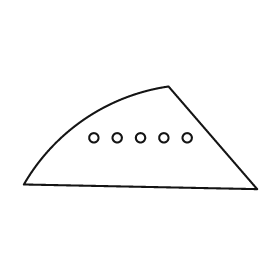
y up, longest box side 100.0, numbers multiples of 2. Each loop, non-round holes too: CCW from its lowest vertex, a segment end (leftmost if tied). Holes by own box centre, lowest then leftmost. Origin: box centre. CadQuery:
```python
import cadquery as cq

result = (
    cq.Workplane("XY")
    .moveTo(50.0, -22.0)
    .lineTo(12.0, 22.0)
    .threePointArc((-24.0, 8.0), (-50.0, -20.0))
    .close()
    .moveTo(-20.0, 0.0)
    .circle(2.0)
    .moveTo(-10.0, 0.0)
    .circle(2.0)
    .moveTo(0.0, 0.0)
    .circle(2.0)
    .moveTo(10.0, 0.0)
    .circle(2.0)
    .moveTo(20.0, 0.0)
    .circle(2.0)
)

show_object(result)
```